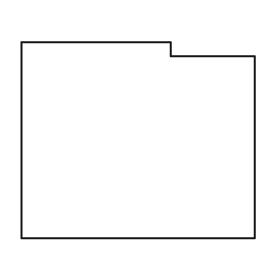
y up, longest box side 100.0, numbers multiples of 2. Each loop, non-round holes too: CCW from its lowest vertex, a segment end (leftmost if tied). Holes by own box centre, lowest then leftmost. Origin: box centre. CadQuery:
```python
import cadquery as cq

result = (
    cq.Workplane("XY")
    .moveTo(-50.0, -42.0)
    .lineTo(50.0, -42.0)
    .lineTo(50.0, 36.0)
    .lineTo(14.0, 36.0)
    .lineTo(14.0, 42.0)
    .lineTo(-50.0, 42.0)
    .close()
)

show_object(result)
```